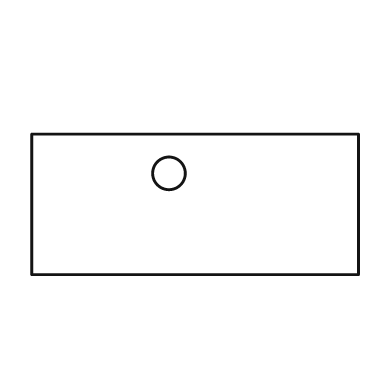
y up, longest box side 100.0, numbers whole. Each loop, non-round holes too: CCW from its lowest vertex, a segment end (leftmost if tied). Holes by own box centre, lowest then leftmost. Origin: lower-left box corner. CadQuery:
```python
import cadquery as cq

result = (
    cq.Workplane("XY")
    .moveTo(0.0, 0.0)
    .lineTo(100.0, 0.0)
    .lineTo(100.0, 43.0)
    .lineTo(0.0, 43.0)
    .close()
    .moveTo(42.0, 31.0)
    .circle(5.0)
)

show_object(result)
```